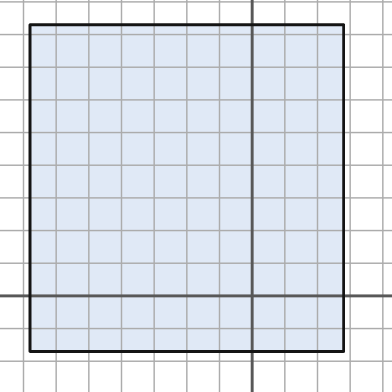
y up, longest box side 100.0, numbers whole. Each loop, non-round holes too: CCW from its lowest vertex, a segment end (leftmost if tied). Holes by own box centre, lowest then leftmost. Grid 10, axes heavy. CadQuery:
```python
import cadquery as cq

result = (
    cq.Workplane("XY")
    .moveTo(-68.0, -17.0)
    .lineTo(28.0, -17.0)
    .lineTo(28.0, 83.0)
    .lineTo(-68.0, 83.0)
    .close()
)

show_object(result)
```